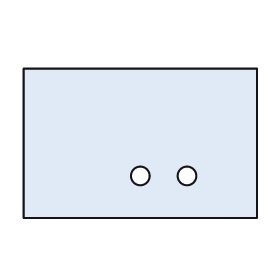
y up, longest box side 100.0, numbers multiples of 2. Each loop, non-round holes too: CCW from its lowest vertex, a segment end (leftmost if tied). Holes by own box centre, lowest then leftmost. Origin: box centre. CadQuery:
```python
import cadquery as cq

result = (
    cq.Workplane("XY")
    .moveTo(-50.0, -32.0)
    .lineTo(50.0, -32.0)
    .lineTo(50.0, 32.0)
    .lineTo(-50.0, 32.0)
    .close()
    .moveTo(0.0, -14.0)
    .circle(4.0)
    .moveTo(20.0, -14.0)
    .circle(4.0)
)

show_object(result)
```